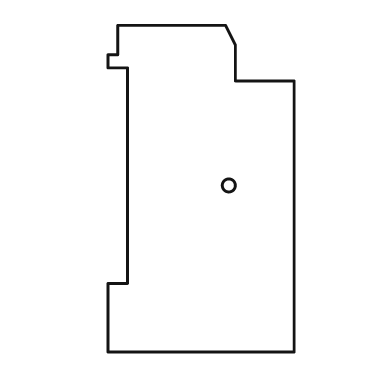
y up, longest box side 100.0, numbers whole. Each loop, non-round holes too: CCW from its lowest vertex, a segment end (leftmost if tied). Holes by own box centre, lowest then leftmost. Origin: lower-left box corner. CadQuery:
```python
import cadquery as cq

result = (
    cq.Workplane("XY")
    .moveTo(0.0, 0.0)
    .lineTo(57.0, 0.0)
    .lineTo(57.0, 83.0)
    .lineTo(39.0, 83.0)
    .lineTo(39.0, 94.0)
    .lineTo(36.0, 100.0)
    .lineTo(3.0, 100.0)
    .lineTo(3.0, 91.0)
    .lineTo(0.0, 91.0)
    .lineTo(0.0, 87.0)
    .lineTo(6.0, 87.0)
    .lineTo(6.0, 21.0)
    .lineTo(0.0, 21.0)
    .close()
    .moveTo(37.0, 51.0)
    .circle(2.0)
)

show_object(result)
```